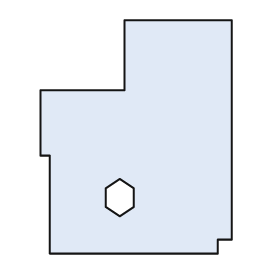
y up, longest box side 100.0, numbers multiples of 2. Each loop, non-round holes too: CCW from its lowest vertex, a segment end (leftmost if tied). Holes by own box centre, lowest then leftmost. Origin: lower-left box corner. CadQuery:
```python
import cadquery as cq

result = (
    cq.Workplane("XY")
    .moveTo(4.0, 0.0)
    .lineTo(76.0, 0.0)
    .lineTo(76.0, 6.0)
    .lineTo(82.0, 6.0)
    .lineTo(82.0, 100.0)
    .lineTo(36.0, 100.0)
    .lineTo(36.0, 70.0)
    .lineTo(0.0, 70.0)
    .lineTo(0.0, 42.0)
    .lineTo(4.0, 42.0)
    .close()
    .moveTo(34.0, 16.0)
    .lineTo(40.0, 20.0)
    .lineTo(40.0, 28.0)
    .lineTo(34.0, 32.0)
    .lineTo(28.0, 28.0)
    .lineTo(28.0, 20.0)
    .close()
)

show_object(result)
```